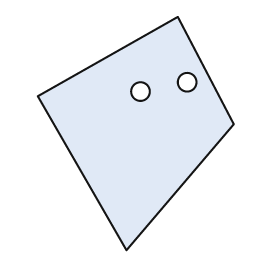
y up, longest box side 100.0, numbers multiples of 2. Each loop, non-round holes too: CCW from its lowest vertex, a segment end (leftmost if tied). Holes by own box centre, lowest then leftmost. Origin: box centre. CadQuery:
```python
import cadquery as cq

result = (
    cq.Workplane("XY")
    .moveTo(-4.0, -50.0)
    .lineTo(42.0, 4.0)
    .lineTo(18.0, 50.0)
    .lineTo(-42.0, 16.0)
    .close()
    .moveTo(2.0, 18.0)
    .circle(4.0)
    .moveTo(22.0, 22.0)
    .circle(4.0)
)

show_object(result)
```